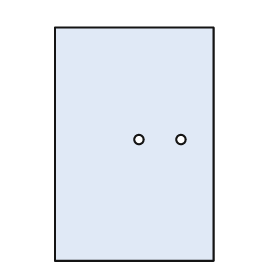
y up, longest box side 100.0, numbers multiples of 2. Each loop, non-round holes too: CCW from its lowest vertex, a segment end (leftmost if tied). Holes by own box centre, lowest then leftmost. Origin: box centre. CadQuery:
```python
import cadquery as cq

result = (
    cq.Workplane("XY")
    .moveTo(-34.0, -50.0)
    .lineTo(34.0, -50.0)
    .lineTo(34.0, 50.0)
    .lineTo(-34.0, 50.0)
    .close()
    .moveTo(2.0, 2.0)
    .circle(2.0)
    .moveTo(20.0, 2.0)
    .circle(2.0)
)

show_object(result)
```